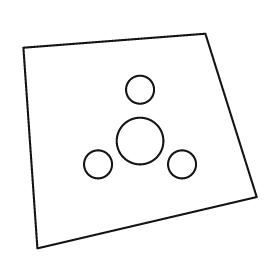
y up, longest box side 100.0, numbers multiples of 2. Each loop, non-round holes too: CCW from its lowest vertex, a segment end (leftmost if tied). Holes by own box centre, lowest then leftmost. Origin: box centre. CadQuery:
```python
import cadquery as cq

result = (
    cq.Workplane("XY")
    .moveTo(-44.0, -46.0)
    .lineTo(50.0, -24.0)
    .lineTo(28.0, 46.0)
    .lineTo(-50.0, 40.0)
    .close()
    .moveTo(-18.0, -10.0)
    .circle(6.0)
    .moveTo(18.0, -10.0)
    .circle(6.0)
    .moveTo(0.0, 0.0)
    .circle(10.0)
    .moveTo(0.0, 22.0)
    .circle(6.0)
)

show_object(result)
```